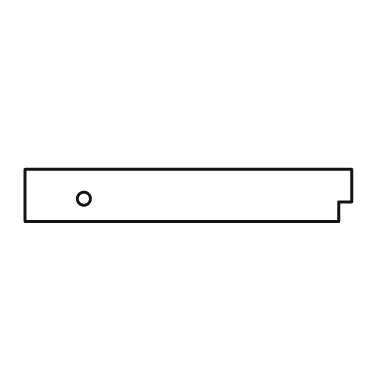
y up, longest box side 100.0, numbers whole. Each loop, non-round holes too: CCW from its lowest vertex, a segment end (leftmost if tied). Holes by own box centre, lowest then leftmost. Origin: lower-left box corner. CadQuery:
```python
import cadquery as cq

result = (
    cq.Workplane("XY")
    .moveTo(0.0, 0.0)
    .lineTo(96.0, 0.0)
    .lineTo(96.0, 6.0)
    .lineTo(100.0, 6.0)
    .lineTo(100.0, 16.0)
    .lineTo(0.0, 16.0)
    .close()
    .moveTo(18.0, 7.0)
    .circle(2.0)
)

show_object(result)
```